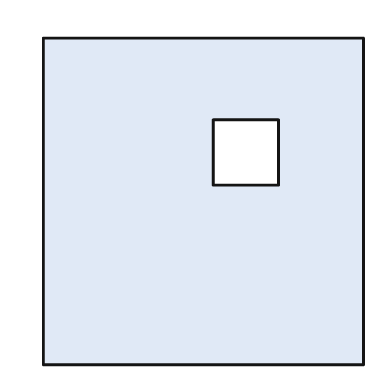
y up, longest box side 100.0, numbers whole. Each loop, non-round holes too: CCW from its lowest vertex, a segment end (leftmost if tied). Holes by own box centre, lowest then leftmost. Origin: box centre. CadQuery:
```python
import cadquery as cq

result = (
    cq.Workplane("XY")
    .moveTo(-49.0, -50.0)
    .lineTo(49.0, -50.0)
    .lineTo(49.0, 50.0)
    .lineTo(-49.0, 50.0)
    .close()
    .moveTo(3.0, 5.0)
    .lineTo(23.0, 5.0)
    .lineTo(23.0, 25.0)
    .lineTo(3.0, 25.0)
    .close()
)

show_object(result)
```